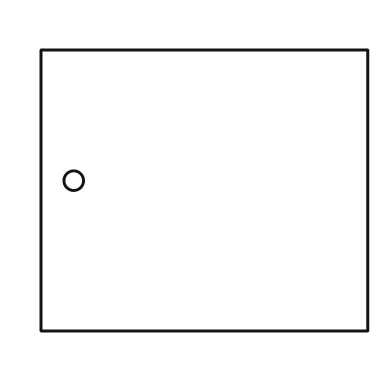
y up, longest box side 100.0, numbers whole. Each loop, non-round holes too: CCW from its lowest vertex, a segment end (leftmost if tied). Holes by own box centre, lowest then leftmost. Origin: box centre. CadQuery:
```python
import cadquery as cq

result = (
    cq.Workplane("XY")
    .moveTo(-50.0, -43.0)
    .lineTo(50.0, -43.0)
    .lineTo(50.0, 43.0)
    .lineTo(-50.0, 43.0)
    .close()
    .moveTo(-40.0, 3.0)
    .circle(3.0)
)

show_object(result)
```